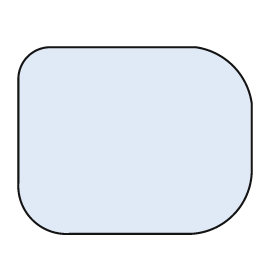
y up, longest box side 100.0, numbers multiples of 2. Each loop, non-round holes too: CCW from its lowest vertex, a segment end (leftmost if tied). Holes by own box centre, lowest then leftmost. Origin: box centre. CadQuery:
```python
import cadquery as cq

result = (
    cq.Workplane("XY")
    .moveTo(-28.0, -40.0)
    .lineTo(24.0, -40.0)
    .threePointArc((42.0, -32.0), (50.0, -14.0))
    .lineTo(50.0, 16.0)
    .threePointArc((42.0, 32.0), (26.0, 40.0))
    .lineTo(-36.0, 40.0)
    .threePointArc((-46.0, 36.0), (-50.0, 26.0))
    .lineTo(-50.0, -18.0)
    .threePointArc((-44.0, -34.0), (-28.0, -40.0))
    .close()
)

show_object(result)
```